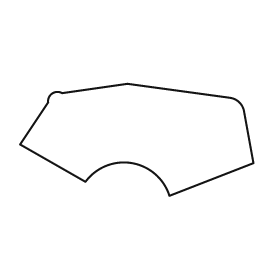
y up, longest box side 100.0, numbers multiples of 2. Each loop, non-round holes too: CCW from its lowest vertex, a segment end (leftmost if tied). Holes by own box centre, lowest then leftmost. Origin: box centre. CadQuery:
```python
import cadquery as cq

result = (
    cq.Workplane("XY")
    .moveTo(14.0, -24.0)
    .lineTo(50.0, -10.0)
    .lineTo(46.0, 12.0)
    .threePointArc((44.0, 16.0), (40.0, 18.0))
    .lineTo(-4.0, 24.0)
    .lineTo(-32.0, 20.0)
    .threePointArc((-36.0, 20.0), (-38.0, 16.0))
    .lineTo(-50.0, -2.0)
    .lineTo(-22.0, -18.0)
    .threePointArc((-2.0, -10.0), (14.0, -24.0))
    .close()
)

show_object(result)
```